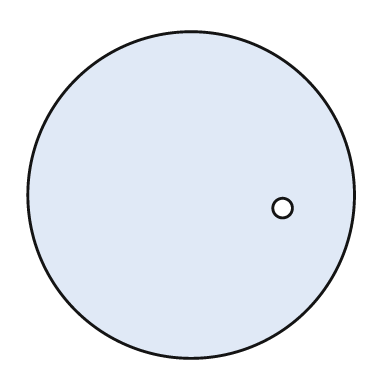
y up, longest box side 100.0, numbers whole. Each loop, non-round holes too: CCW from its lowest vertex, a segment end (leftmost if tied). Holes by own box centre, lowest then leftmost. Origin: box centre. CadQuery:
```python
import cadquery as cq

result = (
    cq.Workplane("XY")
    .moveTo(0.0, 0.0)
    .circle(50.0)
    .moveTo(28.0, -4.0)
    .circle(3.0)
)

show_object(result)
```